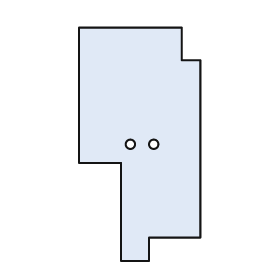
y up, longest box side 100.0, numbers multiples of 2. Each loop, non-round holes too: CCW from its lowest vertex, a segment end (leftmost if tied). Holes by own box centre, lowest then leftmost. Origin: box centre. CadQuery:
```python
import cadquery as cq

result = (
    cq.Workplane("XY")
    .moveTo(-8.0, -50.0)
    .lineTo(4.0, -50.0)
    .lineTo(4.0, -40.0)
    .lineTo(26.0, -40.0)
    .lineTo(26.0, 36.0)
    .lineTo(18.0, 36.0)
    .lineTo(18.0, 50.0)
    .lineTo(-26.0, 50.0)
    .lineTo(-26.0, -8.0)
    .lineTo(-8.0, -8.0)
    .close()
    .moveTo(-4.0, 0.0)
    .circle(2.0)
    .moveTo(6.0, 0.0)
    .circle(2.0)
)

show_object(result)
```